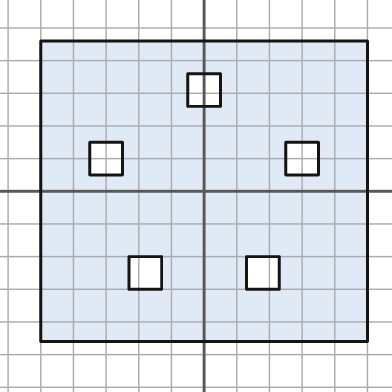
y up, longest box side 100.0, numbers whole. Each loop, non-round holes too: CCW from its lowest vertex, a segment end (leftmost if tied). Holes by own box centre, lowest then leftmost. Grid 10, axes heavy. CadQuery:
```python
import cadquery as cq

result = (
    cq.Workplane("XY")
    .moveTo(-50.0, -46.0)
    .lineTo(50.0, -46.0)
    .lineTo(50.0, 46.0)
    .lineTo(-50.0, 46.0)
    .close()
    .moveTo(-23.0, -30.0)
    .lineTo(-13.0, -30.0)
    .lineTo(-13.0, -20.0)
    .lineTo(-23.0, -20.0)
    .close()
    .moveTo(13.0, -30.0)
    .lineTo(23.0, -30.0)
    .lineTo(23.0, -20.0)
    .lineTo(13.0, -20.0)
    .close()
    .moveTo(-35.0, 5.0)
    .lineTo(-25.0, 5.0)
    .lineTo(-25.0, 15.0)
    .lineTo(-35.0, 15.0)
    .close()
    .moveTo(25.0, 5.0)
    .lineTo(35.0, 5.0)
    .lineTo(35.0, 15.0)
    .lineTo(25.0, 15.0)
    .close()
    .moveTo(-5.0, 26.0)
    .lineTo(5.0, 26.0)
    .lineTo(5.0, 36.0)
    .lineTo(-5.0, 36.0)
    .close()
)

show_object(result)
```